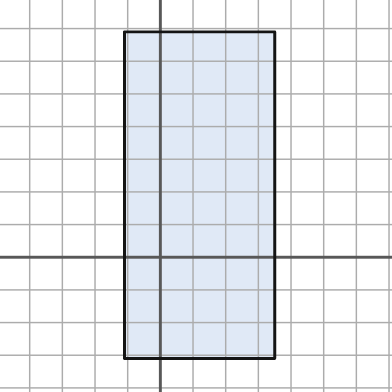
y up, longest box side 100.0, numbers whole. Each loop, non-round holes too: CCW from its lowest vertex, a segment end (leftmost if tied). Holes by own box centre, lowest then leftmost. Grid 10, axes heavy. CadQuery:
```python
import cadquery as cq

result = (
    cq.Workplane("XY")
    .moveTo(-11.0, -31.0)
    .lineTo(35.0, -31.0)
    .lineTo(35.0, 69.0)
    .lineTo(-11.0, 69.0)
    .close()
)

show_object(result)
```